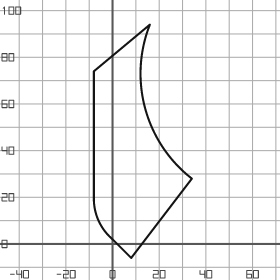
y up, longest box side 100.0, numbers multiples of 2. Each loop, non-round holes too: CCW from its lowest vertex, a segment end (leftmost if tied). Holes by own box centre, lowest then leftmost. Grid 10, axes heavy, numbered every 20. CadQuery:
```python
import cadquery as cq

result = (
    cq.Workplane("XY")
    .moveTo(8.0, -6.0)
    .lineTo(34.0, 28.0)
    .threePointArc((14.0, 58.0), (16.0, 94.0))
    .lineTo(-8.0, 74.0)
    .lineTo(-8.0, 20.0)
    .threePointArc((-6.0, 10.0), (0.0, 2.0))
    .close()
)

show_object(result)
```